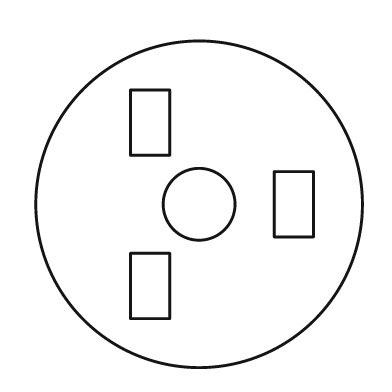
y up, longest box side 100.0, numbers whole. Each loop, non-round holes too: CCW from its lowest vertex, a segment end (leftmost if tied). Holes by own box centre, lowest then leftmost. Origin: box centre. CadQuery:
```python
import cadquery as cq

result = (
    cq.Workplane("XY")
    .moveTo(0.0, 0.0)
    .circle(50.0)
    .moveTo(-21.0, -35.0)
    .lineTo(-9.0, -35.0)
    .lineTo(-9.0, -15.0)
    .lineTo(-21.0, -15.0)
    .close()
    .moveTo(0.0, 0.0)
    .circle(11.0)
    .moveTo(23.0, -10.0)
    .lineTo(35.0, -10.0)
    .lineTo(35.0, 10.0)
    .lineTo(23.0, 10.0)
    .close()
    .moveTo(-21.0, 15.0)
    .lineTo(-9.0, 15.0)
    .lineTo(-9.0, 35.0)
    .lineTo(-21.0, 35.0)
    .close()
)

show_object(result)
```